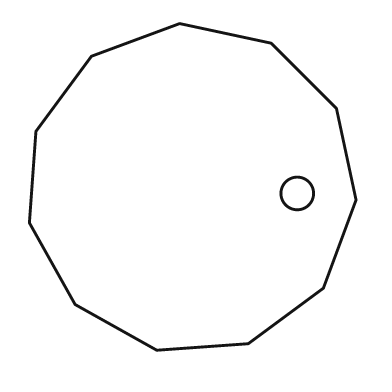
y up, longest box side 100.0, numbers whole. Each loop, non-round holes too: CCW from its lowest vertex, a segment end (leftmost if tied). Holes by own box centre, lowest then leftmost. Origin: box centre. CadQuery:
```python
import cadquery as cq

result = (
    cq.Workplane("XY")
    .moveTo(-11.0, -50.0)
    .lineTo(17.0, -48.0)
    .lineTo(40.0, -31.0)
    .lineTo(50.0, -4.0)
    .lineTo(44.0, 24.0)
    .lineTo(24.0, 44.0)
    .lineTo(-4.0, 50.0)
    .lineTo(-31.0, 40.0)
    .lineTo(-48.0, 17.0)
    .lineTo(-50.0, -11.0)
    .lineTo(-36.0, -36.0)
    .close()
    .moveTo(32.0, -2.0)
    .circle(5.0)
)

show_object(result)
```